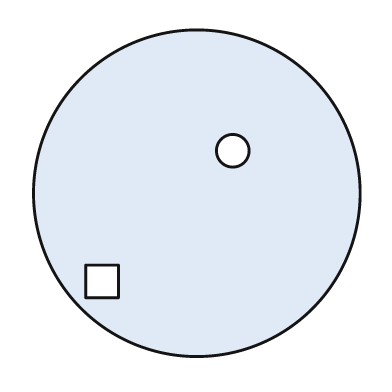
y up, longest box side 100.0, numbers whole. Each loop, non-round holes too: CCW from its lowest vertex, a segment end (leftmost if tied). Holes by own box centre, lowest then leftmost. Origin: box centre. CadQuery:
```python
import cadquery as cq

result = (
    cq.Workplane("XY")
    .moveTo(0.0, 0.0)
    .circle(50.0)
    .moveTo(-34.0, -32.0)
    .lineTo(-24.0, -32.0)
    .lineTo(-24.0, -22.0)
    .lineTo(-34.0, -22.0)
    .close()
    .moveTo(11.0, 13.0)
    .circle(5.0)
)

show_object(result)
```